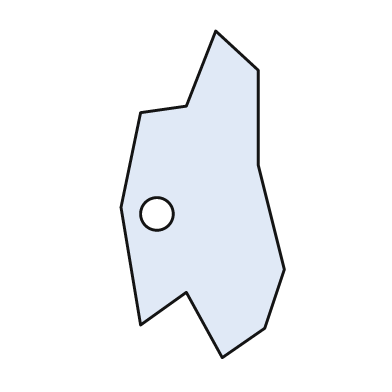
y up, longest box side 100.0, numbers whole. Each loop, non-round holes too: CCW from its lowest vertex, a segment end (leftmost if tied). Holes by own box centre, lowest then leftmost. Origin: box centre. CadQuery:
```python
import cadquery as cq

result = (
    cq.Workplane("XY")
    .moveTo(6.0, -50.0)
    .lineTo(19.0, -41.0)
    .lineTo(25.0, -23.0)
    .lineTo(17.0, 9.0)
    .lineTo(17.0, 38.0)
    .lineTo(4.0, 50.0)
    .lineTo(-5.0, 27.0)
    .lineTo(-19.0, 25.0)
    .lineTo(-25.0, -4.0)
    .lineTo(-19.0, -40.0)
    .lineTo(-5.0, -30.0)
    .close()
    .moveTo(-14.0, -6.0)
    .circle(5.0)
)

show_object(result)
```